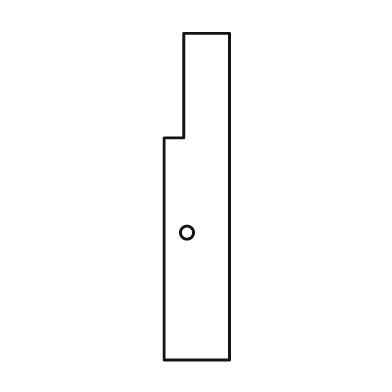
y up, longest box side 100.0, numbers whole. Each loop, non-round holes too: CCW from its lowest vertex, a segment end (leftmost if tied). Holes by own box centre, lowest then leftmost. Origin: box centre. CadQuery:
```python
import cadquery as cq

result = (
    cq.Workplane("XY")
    .moveTo(-10.0, -50.0)
    .lineTo(10.0, -50.0)
    .lineTo(10.0, 50.0)
    .lineTo(-4.0, 50.0)
    .lineTo(-4.0, 18.0)
    .lineTo(-10.0, 18.0)
    .close()
    .moveTo(-3.0, -11.0)
    .circle(2.0)
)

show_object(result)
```